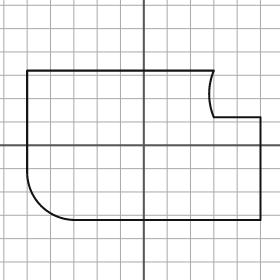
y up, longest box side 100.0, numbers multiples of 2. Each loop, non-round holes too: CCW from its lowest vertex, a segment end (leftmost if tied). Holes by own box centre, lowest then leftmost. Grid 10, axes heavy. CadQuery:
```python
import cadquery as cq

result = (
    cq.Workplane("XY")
    .moveTo(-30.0, -32.0)
    .lineTo(50.0, -32.0)
    .lineTo(50.0, 12.0)
    .lineTo(30.0, 12.0)
    .threePointArc((28.0, 22.0), (30.0, 32.0))
    .lineTo(-50.0, 32.0)
    .lineTo(-50.0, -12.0)
    .threePointArc((-44.0, -26.0), (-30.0, -32.0))
    .close()
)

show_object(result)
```